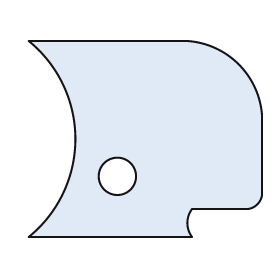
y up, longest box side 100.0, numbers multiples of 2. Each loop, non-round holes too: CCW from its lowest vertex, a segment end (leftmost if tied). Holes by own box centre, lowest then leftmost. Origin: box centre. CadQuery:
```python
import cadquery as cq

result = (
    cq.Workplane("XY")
    .moveTo(-50.0, -42.0)
    .lineTo(20.0, -42.0)
    .threePointArc((18.0, -36.0), (20.0, -30.0))
    .lineTo(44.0, -30.0)
    .threePointArc((48.0, -28.0), (50.0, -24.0))
    .lineTo(50.0, 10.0)
    .threePointArc((40.0, 32.0), (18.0, 42.0))
    .lineTo(-50.0, 42.0)
    .threePointArc((-30.0, 0.0), (-50.0, -42.0))
    .close()
    .moveTo(-12.0, -16.0)
    .circle(8.0)
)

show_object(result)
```